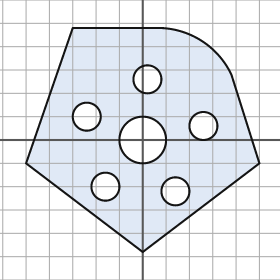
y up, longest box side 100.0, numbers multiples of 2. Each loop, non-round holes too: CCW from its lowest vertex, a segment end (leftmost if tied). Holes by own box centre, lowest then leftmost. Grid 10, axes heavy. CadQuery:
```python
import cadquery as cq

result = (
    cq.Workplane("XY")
    .moveTo(0.0, -48.0)
    .lineTo(50.0, -10.0)
    .lineTo(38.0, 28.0)
    .threePointArc((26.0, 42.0), (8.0, 48.0))
    .lineTo(-30.0, 48.0)
    .lineTo(-50.0, -10.0)
    .close()
    .moveTo(14.0, -22.0)
    .circle(6.0)
    .moveTo(-16.0, -20.0)
    .circle(6.0)
    .moveTo(0.0, 0.0)
    .circle(10.0)
    .moveTo(26.0, 6.0)
    .circle(6.0)
    .moveTo(-24.0, 10.0)
    .circle(6.0)
    .moveTo(2.0, 26.0)
    .circle(6.0)
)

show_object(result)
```